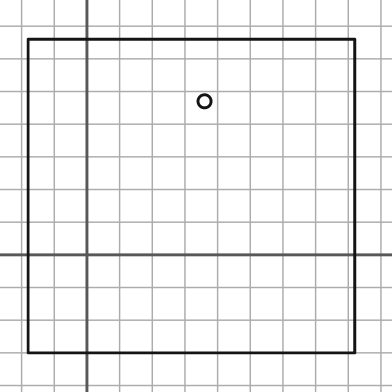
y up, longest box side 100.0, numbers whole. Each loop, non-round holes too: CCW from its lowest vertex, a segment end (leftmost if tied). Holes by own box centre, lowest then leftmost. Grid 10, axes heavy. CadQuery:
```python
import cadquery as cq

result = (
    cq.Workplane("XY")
    .moveTo(-18.0, -30.0)
    .lineTo(82.0, -30.0)
    .lineTo(82.0, 66.0)
    .lineTo(-18.0, 66.0)
    .close()
    .moveTo(36.0, 47.0)
    .circle(2.0)
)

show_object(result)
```